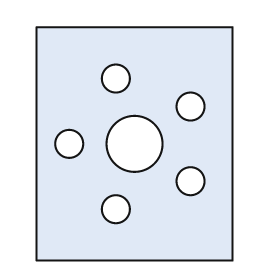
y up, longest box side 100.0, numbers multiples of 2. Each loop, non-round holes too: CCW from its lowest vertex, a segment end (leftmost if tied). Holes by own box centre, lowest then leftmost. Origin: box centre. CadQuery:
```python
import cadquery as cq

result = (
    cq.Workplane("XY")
    .moveTo(-42.0, -50.0)
    .lineTo(42.0, -50.0)
    .lineTo(42.0, 50.0)
    .lineTo(-42.0, 50.0)
    .close()
    .moveTo(-8.0, -28.0)
    .circle(6.0)
    .moveTo(24.0, -16.0)
    .circle(6.0)
    .moveTo(-28.0, 0.0)
    .circle(6.0)
    .moveTo(0.0, 0.0)
    .circle(12.0)
    .moveTo(24.0, 16.0)
    .circle(6.0)
    .moveTo(-8.0, 28.0)
    .circle(6.0)
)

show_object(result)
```